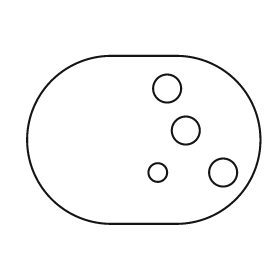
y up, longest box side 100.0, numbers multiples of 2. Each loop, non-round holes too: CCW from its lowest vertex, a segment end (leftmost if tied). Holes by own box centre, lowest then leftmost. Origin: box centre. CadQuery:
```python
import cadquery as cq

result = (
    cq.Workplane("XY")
    .moveTo(-14.0, -36.0)
    .lineTo(14.0, -36.0)
    .threePointArc((50.0, 0.0), (14.0, 36.0))
    .lineTo(-14.0, 36.0)
    .threePointArc((-50.0, 0.0), (-14.0, -36.0))
    .close()
    .moveTo(6.0, -14.0)
    .circle(4.0)
    .moveTo(34.0, -14.0)
    .circle(6.0)
    .moveTo(18.0, 4.0)
    .circle(6.0)
    .moveTo(10.0, 22.0)
    .circle(6.0)
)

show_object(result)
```